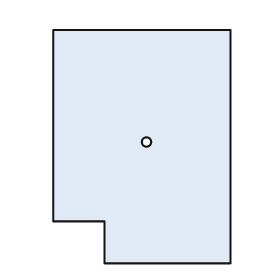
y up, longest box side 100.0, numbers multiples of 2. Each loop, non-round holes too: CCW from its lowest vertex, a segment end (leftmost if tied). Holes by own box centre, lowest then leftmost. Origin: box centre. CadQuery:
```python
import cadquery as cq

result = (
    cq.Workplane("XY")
    .moveTo(-16.0, -50.0)
    .lineTo(38.0, -50.0)
    .lineTo(38.0, 50.0)
    .lineTo(-38.0, 50.0)
    .lineTo(-38.0, -32.0)
    .lineTo(-16.0, -32.0)
    .close()
    .moveTo(2.0, 2.0)
    .circle(2.0)
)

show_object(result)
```